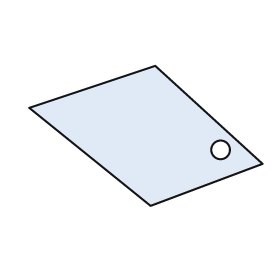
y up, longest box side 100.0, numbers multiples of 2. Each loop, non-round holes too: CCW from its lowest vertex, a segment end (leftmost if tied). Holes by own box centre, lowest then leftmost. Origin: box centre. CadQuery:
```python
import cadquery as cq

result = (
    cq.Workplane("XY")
    .moveTo(2.0, -30.0)
    .lineTo(50.0, -12.0)
    .lineTo(4.0, 30.0)
    .lineTo(-50.0, 12.0)
    .close()
    .moveTo(32.0, -6.0)
    .circle(4.0)
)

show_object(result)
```